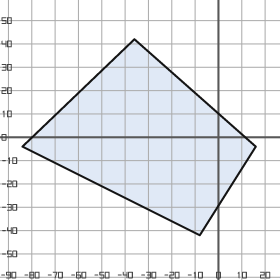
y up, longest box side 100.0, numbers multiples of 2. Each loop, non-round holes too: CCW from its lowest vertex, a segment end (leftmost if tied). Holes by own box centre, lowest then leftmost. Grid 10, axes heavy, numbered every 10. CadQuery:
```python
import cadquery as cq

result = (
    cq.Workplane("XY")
    .moveTo(-8.0, -42.0)
    .lineTo(16.0, -4.0)
    .lineTo(-36.0, 42.0)
    .lineTo(-84.0, -4.0)
    .close()
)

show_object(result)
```